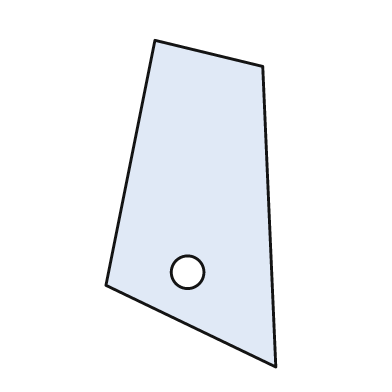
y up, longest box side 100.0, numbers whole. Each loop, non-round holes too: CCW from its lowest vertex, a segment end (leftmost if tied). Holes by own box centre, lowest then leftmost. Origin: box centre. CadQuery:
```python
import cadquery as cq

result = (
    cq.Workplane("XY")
    .moveTo(26.0, -50.0)
    .lineTo(22.0, 42.0)
    .lineTo(-11.0, 50.0)
    .lineTo(-26.0, -25.0)
    .close()
    .moveTo(-1.0, -21.0)
    .circle(5.0)
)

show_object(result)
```